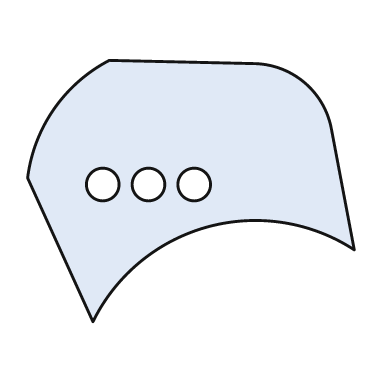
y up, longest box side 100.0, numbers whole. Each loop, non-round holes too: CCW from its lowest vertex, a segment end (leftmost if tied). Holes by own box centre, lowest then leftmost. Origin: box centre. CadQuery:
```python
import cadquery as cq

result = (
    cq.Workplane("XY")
    .moveTo(-30.0, -40.0)
    .threePointArc((5.0, -11.0), (50.0, -18.0))
    .lineTo(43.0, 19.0)
    .threePointArc((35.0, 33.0), (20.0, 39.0))
    .lineTo(-25.0, 40.0)
    .threePointArc((-42.0, 25.0), (-50.0, 4.0))
    .close()
    .moveTo(-27.0, 2.0)
    .circle(5.0)
    .moveTo(-13.0, 2.0)
    .circle(5.0)
    .moveTo(1.0, 2.0)
    .circle(5.0)
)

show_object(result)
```